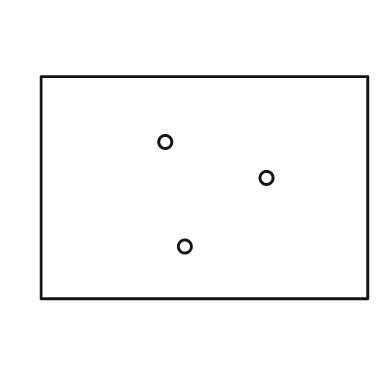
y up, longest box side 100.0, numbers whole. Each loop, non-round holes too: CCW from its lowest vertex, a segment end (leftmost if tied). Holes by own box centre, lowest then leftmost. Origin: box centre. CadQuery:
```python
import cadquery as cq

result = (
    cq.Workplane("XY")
    .moveTo(-50.0, -34.0)
    .lineTo(50.0, -34.0)
    .lineTo(50.0, 34.0)
    .lineTo(-50.0, 34.0)
    .close()
    .moveTo(-6.0, -18.0)
    .circle(2.0)
    .moveTo(19.0, 3.0)
    .circle(2.0)
    .moveTo(-12.0, 14.0)
    .circle(2.0)
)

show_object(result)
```